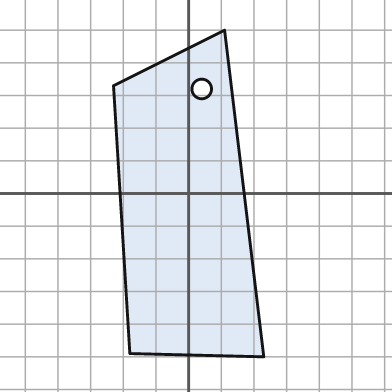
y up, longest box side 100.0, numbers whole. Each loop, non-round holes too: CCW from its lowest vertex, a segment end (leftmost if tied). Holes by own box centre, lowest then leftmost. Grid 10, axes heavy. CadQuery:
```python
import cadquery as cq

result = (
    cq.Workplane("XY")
    .moveTo(23.0, -50.0)
    .lineTo(11.0, 50.0)
    .lineTo(-23.0, 33.0)
    .lineTo(-18.0, -49.0)
    .close()
    .moveTo(4.0, 32.0)
    .circle(3.0)
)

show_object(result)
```